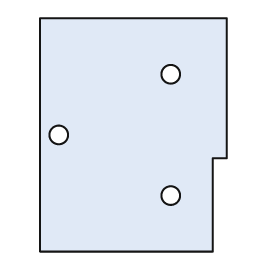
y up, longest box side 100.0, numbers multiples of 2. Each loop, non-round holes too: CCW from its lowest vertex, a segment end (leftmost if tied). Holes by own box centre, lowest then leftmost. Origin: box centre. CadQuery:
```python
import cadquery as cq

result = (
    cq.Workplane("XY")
    .moveTo(-40.0, -50.0)
    .lineTo(34.0, -50.0)
    .lineTo(34.0, -10.0)
    .lineTo(40.0, -10.0)
    .lineTo(40.0, 50.0)
    .lineTo(-40.0, 50.0)
    .close()
    .moveTo(16.0, -26.0)
    .circle(4.0)
    .moveTo(-32.0, 0.0)
    .circle(4.0)
    .moveTo(16.0, 26.0)
    .circle(4.0)
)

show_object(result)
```